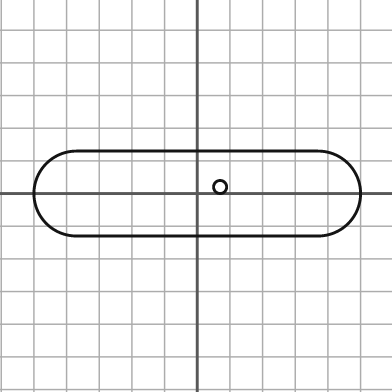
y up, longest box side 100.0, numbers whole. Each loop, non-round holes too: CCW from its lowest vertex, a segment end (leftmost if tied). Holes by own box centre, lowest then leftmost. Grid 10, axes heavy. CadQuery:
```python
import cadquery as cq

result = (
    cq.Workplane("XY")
    .moveTo(-37.0, -13.0)
    .lineTo(37.0, -13.0)
    .threePointArc((50.0, 0.0), (37.0, 13.0))
    .lineTo(-37.0, 13.0)
    .threePointArc((-50.0, 0.0), (-37.0, -13.0))
    .close()
    .moveTo(7.0, 2.0)
    .circle(2.0)
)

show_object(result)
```